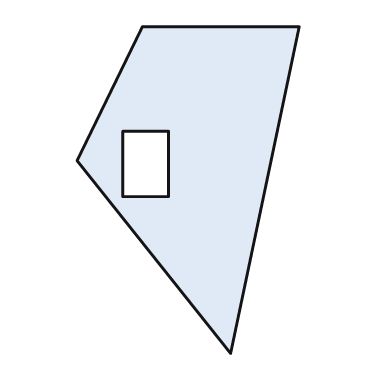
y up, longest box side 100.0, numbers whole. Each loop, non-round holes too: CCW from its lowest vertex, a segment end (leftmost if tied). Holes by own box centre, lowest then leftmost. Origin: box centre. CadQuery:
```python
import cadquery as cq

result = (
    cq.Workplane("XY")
    .moveTo(13.0, -50.0)
    .lineTo(34.0, 50.0)
    .lineTo(-14.0, 50.0)
    .lineTo(-34.0, 9.0)
    .close()
    .moveTo(-20.0, -2.0)
    .lineTo(-6.0, -2.0)
    .lineTo(-6.0, 18.0)
    .lineTo(-20.0, 18.0)
    .close()
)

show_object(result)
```